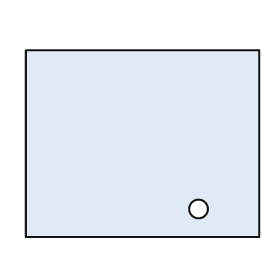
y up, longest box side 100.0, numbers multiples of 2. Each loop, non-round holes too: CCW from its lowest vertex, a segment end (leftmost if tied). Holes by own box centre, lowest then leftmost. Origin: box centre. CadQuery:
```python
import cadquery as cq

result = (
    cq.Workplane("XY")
    .moveTo(-50.0, -40.0)
    .lineTo(50.0, -40.0)
    .lineTo(50.0, 40.0)
    .lineTo(-50.0, 40.0)
    .close()
    .moveTo(24.0, -28.0)
    .circle(4.0)
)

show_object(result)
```